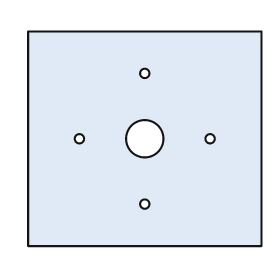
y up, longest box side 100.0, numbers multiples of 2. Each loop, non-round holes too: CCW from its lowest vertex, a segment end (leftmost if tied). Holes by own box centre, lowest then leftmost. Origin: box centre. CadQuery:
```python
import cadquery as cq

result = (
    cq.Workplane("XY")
    .moveTo(-50.0, -46.0)
    .lineTo(50.0, -46.0)
    .lineTo(50.0, 46.0)
    .lineTo(-50.0, 46.0)
    .close()
    .moveTo(0.0, -28.0)
    .circle(2.0)
    .moveTo(-28.0, 0.0)
    .circle(2.0)
    .moveTo(0.0, 0.0)
    .circle(8.0)
    .moveTo(28.0, 0.0)
    .circle(2.0)
    .moveTo(0.0, 28.0)
    .circle(2.0)
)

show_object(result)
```